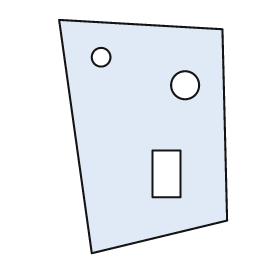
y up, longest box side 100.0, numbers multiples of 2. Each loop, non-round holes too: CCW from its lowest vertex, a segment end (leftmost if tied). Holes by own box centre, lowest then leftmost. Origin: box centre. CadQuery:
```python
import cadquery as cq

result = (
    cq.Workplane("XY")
    .moveTo(-22.0, -50.0)
    .lineTo(36.0, -36.0)
    .lineTo(34.0, 46.0)
    .lineTo(-36.0, 50.0)
    .close()
    .moveTo(4.0, -26.0)
    .lineTo(16.0, -26.0)
    .lineTo(16.0, -6.0)
    .lineTo(4.0, -6.0)
    .close()
    .moveTo(18.0, 22.0)
    .circle(6.0)
    .moveTo(-18.0, 34.0)
    .circle(4.0)
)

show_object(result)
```